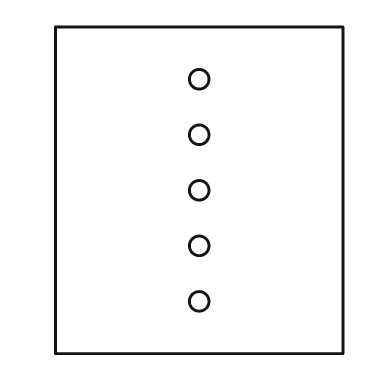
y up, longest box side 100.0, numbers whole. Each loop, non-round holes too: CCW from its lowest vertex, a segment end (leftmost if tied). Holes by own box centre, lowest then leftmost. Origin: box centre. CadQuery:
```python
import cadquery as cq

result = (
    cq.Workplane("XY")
    .moveTo(-44.0, -50.0)
    .lineTo(44.0, -50.0)
    .lineTo(44.0, 50.0)
    .lineTo(-44.0, 50.0)
    .close()
    .moveTo(0.0, -34.0)
    .circle(3.0)
    .moveTo(0.0, -17.0)
    .circle(3.0)
    .moveTo(0.0, 0.0)
    .circle(3.0)
    .moveTo(0.0, 17.0)
    .circle(3.0)
    .moveTo(0.0, 34.0)
    .circle(3.0)
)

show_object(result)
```